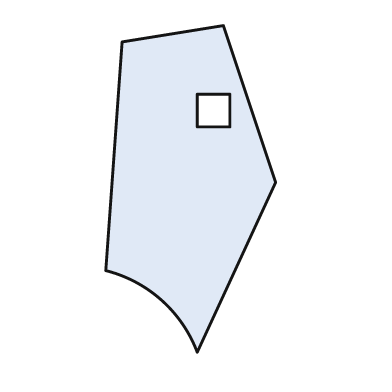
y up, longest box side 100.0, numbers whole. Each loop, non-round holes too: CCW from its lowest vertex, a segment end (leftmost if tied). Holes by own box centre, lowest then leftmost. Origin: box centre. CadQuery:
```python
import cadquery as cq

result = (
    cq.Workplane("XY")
    .moveTo(2.0, -50.0)
    .lineTo(26.0, 2.0)
    .lineTo(10.0, 50.0)
    .lineTo(-21.0, 45.0)
    .lineTo(-26.0, -25.0)
    .threePointArc((-9.0, -34.0), (2.0, -50.0))
    .close()
    .moveTo(2.0, 19.0)
    .lineTo(12.0, 19.0)
    .lineTo(12.0, 29.0)
    .lineTo(2.0, 29.0)
    .close()
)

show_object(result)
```